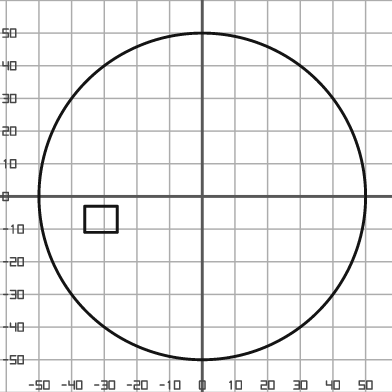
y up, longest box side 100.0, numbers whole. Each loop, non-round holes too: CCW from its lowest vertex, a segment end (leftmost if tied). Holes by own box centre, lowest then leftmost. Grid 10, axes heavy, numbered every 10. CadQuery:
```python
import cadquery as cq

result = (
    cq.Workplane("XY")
    .moveTo(0.0, 0.0)
    .circle(50.0)
    .moveTo(-36.0, -11.0)
    .lineTo(-26.0, -11.0)
    .lineTo(-26.0, -3.0)
    .lineTo(-36.0, -3.0)
    .close()
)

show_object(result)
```